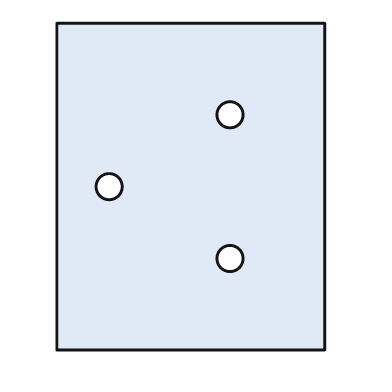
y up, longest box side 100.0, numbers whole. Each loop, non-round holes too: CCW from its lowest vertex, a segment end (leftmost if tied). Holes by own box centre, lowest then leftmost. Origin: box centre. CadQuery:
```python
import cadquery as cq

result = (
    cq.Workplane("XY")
    .moveTo(-41.0, -50.0)
    .lineTo(41.0, -50.0)
    .lineTo(41.0, 50.0)
    .lineTo(-41.0, 50.0)
    .close()
    .moveTo(12.0, -22.0)
    .circle(4.0)
    .moveTo(-25.0, 0.0)
    .circle(4.0)
    .moveTo(12.0, 22.0)
    .circle(4.0)
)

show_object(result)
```